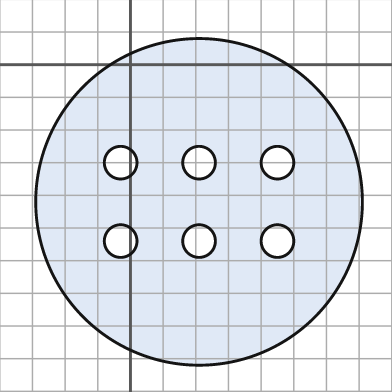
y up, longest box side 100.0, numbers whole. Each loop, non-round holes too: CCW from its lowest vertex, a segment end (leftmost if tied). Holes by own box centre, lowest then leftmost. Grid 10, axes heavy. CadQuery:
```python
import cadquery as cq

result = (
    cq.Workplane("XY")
    .moveTo(21.0, -42.0)
    .circle(50.0)
    .moveTo(-3.0, -54.0)
    .circle(5.0)
    .moveTo(21.0, -54.0)
    .circle(5.0)
    .moveTo(45.0, -54.0)
    .circle(5.0)
    .moveTo(-3.0, -30.0)
    .circle(5.0)
    .moveTo(21.0, -30.0)
    .circle(5.0)
    .moveTo(45.0, -30.0)
    .circle(5.0)
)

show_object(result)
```